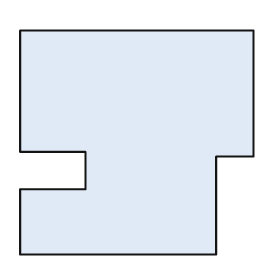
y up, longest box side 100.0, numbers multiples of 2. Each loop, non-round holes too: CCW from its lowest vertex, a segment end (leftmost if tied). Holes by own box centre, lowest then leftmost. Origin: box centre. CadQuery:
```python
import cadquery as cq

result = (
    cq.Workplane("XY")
    .moveTo(-50.0, -48.0)
    .lineTo(34.0, -48.0)
    .lineTo(34.0, -6.0)
    .lineTo(50.0, -6.0)
    .lineTo(50.0, 48.0)
    .lineTo(-50.0, 48.0)
    .lineTo(-50.0, -4.0)
    .lineTo(-22.0, -4.0)
    .lineTo(-22.0, -20.0)
    .lineTo(-50.0, -20.0)
    .close()
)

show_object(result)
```